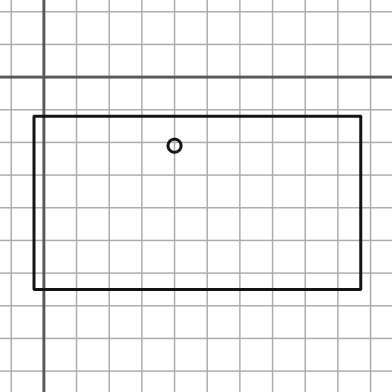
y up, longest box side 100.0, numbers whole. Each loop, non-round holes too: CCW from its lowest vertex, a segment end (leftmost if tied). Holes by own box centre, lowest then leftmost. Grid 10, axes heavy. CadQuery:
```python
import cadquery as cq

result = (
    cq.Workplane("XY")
    .moveTo(-3.0, -65.0)
    .lineTo(97.0, -65.0)
    .lineTo(97.0, -12.0)
    .lineTo(-3.0, -12.0)
    .close()
    .moveTo(40.0, -21.0)
    .circle(2.0)
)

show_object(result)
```